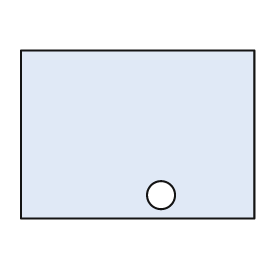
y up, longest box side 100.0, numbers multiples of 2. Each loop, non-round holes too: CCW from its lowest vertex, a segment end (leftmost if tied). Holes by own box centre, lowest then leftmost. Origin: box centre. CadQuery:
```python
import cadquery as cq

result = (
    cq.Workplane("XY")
    .moveTo(-50.0, -36.0)
    .lineTo(50.0, -36.0)
    .lineTo(50.0, 36.0)
    .lineTo(-50.0, 36.0)
    .close()
    .moveTo(10.0, -26.0)
    .circle(6.0)
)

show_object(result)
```